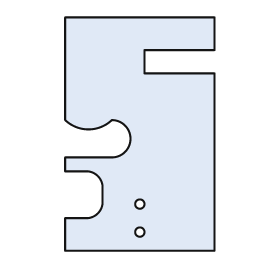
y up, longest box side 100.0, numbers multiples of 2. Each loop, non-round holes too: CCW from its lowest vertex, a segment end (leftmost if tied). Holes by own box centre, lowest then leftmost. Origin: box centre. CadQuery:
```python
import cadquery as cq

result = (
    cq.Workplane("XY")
    .moveTo(-32.0, -50.0)
    .lineTo(32.0, -50.0)
    .lineTo(32.0, 26.0)
    .lineTo(2.0, 26.0)
    .lineTo(2.0, 36.0)
    .lineTo(32.0, 36.0)
    .lineTo(32.0, 50.0)
    .lineTo(-32.0, 50.0)
    .lineTo(-32.0, 6.0)
    .threePointArc((-22.0, 2.0), (-12.0, 6.0))
    .threePointArc((-4.0, -2.0), (-12.0, -10.0))
    .lineTo(-32.0, -10.0)
    .lineTo(-32.0, -16.0)
    .lineTo(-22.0, -16.0)
    .threePointArc((-18.0, -18.0), (-16.0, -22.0))
    .lineTo(-16.0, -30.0)
    .threePointArc((-18.0, -34.0), (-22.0, -36.0))
    .lineTo(-32.0, -36.0)
    .close()
    .moveTo(0.0, -42.0)
    .circle(2.0)
    .moveTo(0.0, -30.0)
    .circle(2.0)
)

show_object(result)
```